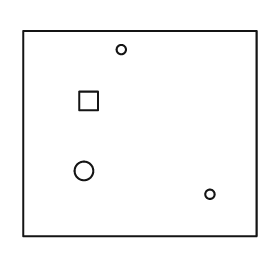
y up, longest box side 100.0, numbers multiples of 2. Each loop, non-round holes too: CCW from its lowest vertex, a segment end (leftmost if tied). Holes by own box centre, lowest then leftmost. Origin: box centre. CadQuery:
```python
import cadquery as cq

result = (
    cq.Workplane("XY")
    .moveTo(-50.0, -44.0)
    .lineTo(50.0, -44.0)
    .lineTo(50.0, 44.0)
    .lineTo(-50.0, 44.0)
    .close()
    .moveTo(30.0, -26.0)
    .circle(2.0)
    .moveTo(-24.0, -16.0)
    .circle(4.0)
    .moveTo(-26.0, 10.0)
    .lineTo(-18.0, 10.0)
    .lineTo(-18.0, 18.0)
    .lineTo(-26.0, 18.0)
    .close()
    .moveTo(-8.0, 36.0)
    .circle(2.0)
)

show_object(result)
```